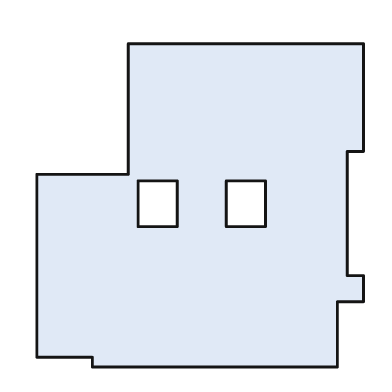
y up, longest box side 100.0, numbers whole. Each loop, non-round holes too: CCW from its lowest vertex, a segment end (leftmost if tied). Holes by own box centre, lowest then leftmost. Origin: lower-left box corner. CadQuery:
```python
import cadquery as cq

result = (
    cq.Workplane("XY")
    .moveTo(17.0, 0.0)
    .lineTo(92.0, 0.0)
    .lineTo(92.0, 20.0)
    .lineTo(100.0, 20.0)
    .lineTo(100.0, 28.0)
    .lineTo(95.0, 28.0)
    .lineTo(95.0, 66.0)
    .lineTo(100.0, 66.0)
    .lineTo(100.0, 99.0)
    .lineTo(28.0, 99.0)
    .lineTo(28.0, 59.0)
    .lineTo(0.0, 59.0)
    .lineTo(0.0, 3.0)
    .lineTo(17.0, 3.0)
    .close()
    .moveTo(31.0, 43.0)
    .lineTo(43.0, 43.0)
    .lineTo(43.0, 57.0)
    .lineTo(31.0, 57.0)
    .close()
    .moveTo(58.0, 43.0)
    .lineTo(70.0, 43.0)
    .lineTo(70.0, 57.0)
    .lineTo(58.0, 57.0)
    .close()
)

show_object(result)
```